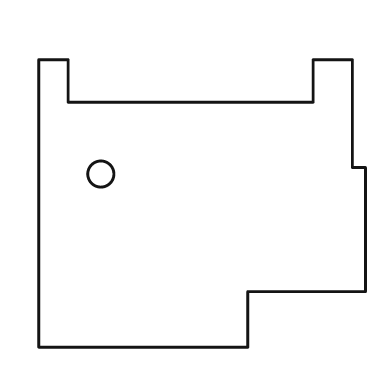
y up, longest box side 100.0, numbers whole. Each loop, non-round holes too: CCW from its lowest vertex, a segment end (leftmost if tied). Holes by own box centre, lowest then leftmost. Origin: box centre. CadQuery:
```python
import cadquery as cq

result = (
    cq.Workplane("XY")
    .moveTo(-50.0, -44.0)
    .lineTo(14.0, -44.0)
    .lineTo(14.0, -27.0)
    .lineTo(50.0, -27.0)
    .lineTo(50.0, 11.0)
    .lineTo(46.0, 11.0)
    .lineTo(46.0, 44.0)
    .lineTo(34.0, 44.0)
    .lineTo(34.0, 31.0)
    .lineTo(-41.0, 31.0)
    .lineTo(-41.0, 44.0)
    .lineTo(-50.0, 44.0)
    .close()
    .moveTo(-31.0, 9.0)
    .circle(4.0)
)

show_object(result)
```